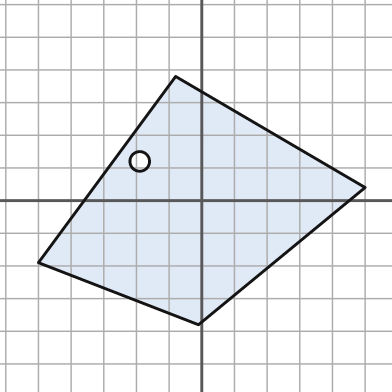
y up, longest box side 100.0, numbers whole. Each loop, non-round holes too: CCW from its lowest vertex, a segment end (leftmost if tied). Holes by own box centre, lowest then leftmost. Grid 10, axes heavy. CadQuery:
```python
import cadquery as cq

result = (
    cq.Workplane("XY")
    .moveTo(-1.0, -38.0)
    .lineTo(50.0, 4.0)
    .lineTo(-8.0, 38.0)
    .lineTo(-50.0, -19.0)
    .close()
    .moveTo(-19.0, 12.0)
    .circle(3.0)
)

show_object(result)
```